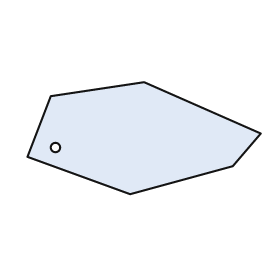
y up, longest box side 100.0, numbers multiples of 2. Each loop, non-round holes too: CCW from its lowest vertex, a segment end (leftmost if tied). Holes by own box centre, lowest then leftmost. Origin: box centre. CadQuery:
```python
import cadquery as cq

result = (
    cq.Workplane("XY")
    .moveTo(-6.0, -24.0)
    .lineTo(38.0, -12.0)
    .lineTo(50.0, 2.0)
    .lineTo(0.0, 24.0)
    .lineTo(-40.0, 18.0)
    .lineTo(-50.0, -8.0)
    .close()
    .moveTo(-38.0, -4.0)
    .circle(2.0)
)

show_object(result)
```